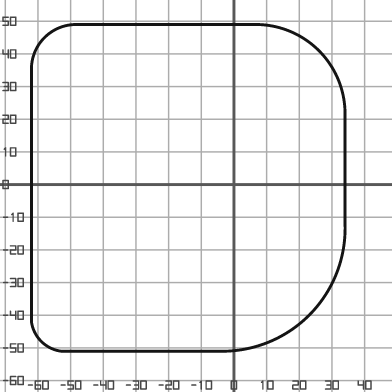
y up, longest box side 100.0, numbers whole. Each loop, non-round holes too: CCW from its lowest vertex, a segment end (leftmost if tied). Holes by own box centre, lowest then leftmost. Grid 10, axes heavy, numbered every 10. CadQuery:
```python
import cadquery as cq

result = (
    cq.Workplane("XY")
    .moveTo(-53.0, -51.0)
    .lineTo(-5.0, -51.0)
    .threePointArc((23.0, -40.0), (34.0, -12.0))
    .lineTo(34.0, 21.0)
    .threePointArc((26.0, 41.0), (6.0, 49.0))
    .lineTo(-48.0, 49.0)
    .threePointArc((-58.0, 45.0), (-62.0, 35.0))
    .lineTo(-62.0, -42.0)
    .threePointArc((-59.0, -48.0), (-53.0, -51.0))
    .close()
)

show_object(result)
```